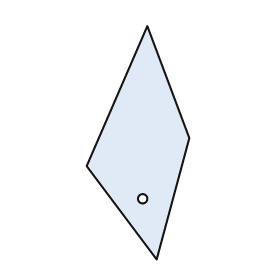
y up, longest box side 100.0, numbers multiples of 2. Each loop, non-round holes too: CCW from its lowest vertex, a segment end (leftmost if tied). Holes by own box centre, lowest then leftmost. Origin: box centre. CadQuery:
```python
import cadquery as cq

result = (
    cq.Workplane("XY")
    .moveTo(8.0, -50.0)
    .lineTo(22.0, 2.0)
    .lineTo(4.0, 50.0)
    .lineTo(-22.0, -10.0)
    .close()
    .moveTo(2.0, -24.0)
    .circle(2.0)
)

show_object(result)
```